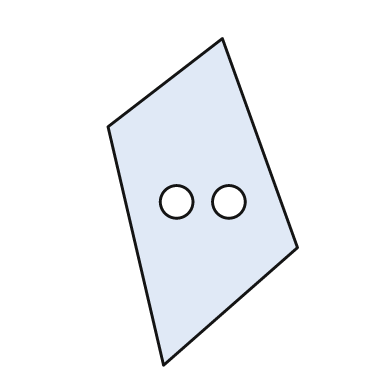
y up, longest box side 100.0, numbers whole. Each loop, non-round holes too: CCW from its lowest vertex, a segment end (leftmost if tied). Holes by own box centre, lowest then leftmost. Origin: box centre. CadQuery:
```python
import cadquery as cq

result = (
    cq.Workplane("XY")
    .moveTo(-12.0, -50.0)
    .lineTo(29.0, -14.0)
    .lineTo(6.0, 50.0)
    .lineTo(-29.0, 23.0)
    .close()
    .moveTo(-8.0, 0.0)
    .circle(5.0)
    .moveTo(8.0, 0.0)
    .circle(5.0)
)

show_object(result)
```